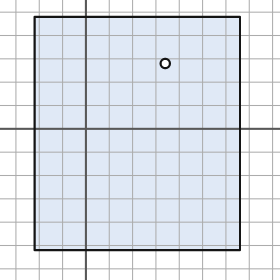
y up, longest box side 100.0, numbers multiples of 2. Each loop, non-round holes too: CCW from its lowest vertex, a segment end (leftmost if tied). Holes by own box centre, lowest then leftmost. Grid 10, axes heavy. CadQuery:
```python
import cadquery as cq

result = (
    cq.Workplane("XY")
    .moveTo(-22.0, -52.0)
    .lineTo(66.0, -52.0)
    .lineTo(66.0, 48.0)
    .lineTo(-22.0, 48.0)
    .close()
    .moveTo(34.0, 28.0)
    .circle(2.0)
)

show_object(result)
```